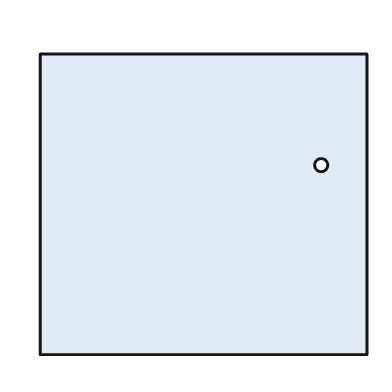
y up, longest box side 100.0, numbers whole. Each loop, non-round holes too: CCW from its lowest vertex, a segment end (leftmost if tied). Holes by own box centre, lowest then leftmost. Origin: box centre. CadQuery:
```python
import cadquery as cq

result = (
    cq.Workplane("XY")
    .moveTo(-50.0, -46.0)
    .lineTo(50.0, -46.0)
    .lineTo(50.0, 46.0)
    .lineTo(-50.0, 46.0)
    .close()
    .moveTo(36.0, 12.0)
    .circle(2.0)
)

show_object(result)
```